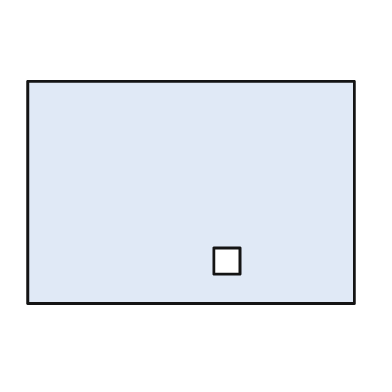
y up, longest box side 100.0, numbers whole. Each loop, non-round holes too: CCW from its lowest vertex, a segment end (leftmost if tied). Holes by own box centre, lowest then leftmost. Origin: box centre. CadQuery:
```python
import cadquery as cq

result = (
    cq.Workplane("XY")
    .moveTo(-50.0, -34.0)
    .lineTo(50.0, -34.0)
    .lineTo(50.0, 34.0)
    .lineTo(-50.0, 34.0)
    .close()
    .moveTo(7.0, -25.0)
    .lineTo(15.0, -25.0)
    .lineTo(15.0, -17.0)
    .lineTo(7.0, -17.0)
    .close()
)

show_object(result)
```